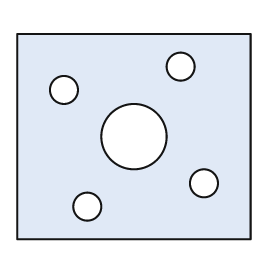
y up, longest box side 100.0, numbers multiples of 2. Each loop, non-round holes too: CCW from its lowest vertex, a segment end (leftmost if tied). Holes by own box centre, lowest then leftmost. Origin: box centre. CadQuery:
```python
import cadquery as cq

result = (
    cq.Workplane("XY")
    .moveTo(-50.0, -44.0)
    .lineTo(50.0, -44.0)
    .lineTo(50.0, 44.0)
    .lineTo(-50.0, 44.0)
    .close()
    .moveTo(-20.0, -30.0)
    .circle(6.0)
    .moveTo(30.0, -20.0)
    .circle(6.0)
    .moveTo(0.0, 0.0)
    .circle(14.0)
    .moveTo(-30.0, 20.0)
    .circle(6.0)
    .moveTo(20.0, 30.0)
    .circle(6.0)
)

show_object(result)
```